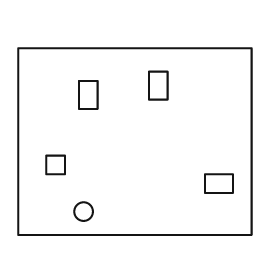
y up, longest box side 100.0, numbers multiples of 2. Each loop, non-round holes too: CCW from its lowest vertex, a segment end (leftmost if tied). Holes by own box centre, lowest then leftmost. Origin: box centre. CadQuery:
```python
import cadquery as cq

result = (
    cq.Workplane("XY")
    .moveTo(-50.0, -40.0)
    .lineTo(50.0, -40.0)
    .lineTo(50.0, 40.0)
    .lineTo(-50.0, 40.0)
    .close()
    .moveTo(-22.0, -30.0)
    .circle(4.0)
    .moveTo(30.0, -22.0)
    .lineTo(42.0, -22.0)
    .lineTo(42.0, -14.0)
    .lineTo(30.0, -14.0)
    .close()
    .moveTo(-38.0, -14.0)
    .lineTo(-30.0, -14.0)
    .lineTo(-30.0, -6.0)
    .lineTo(-38.0, -6.0)
    .close()
    .moveTo(-24.0, 14.0)
    .lineTo(-16.0, 14.0)
    .lineTo(-16.0, 26.0)
    .lineTo(-24.0, 26.0)
    .close()
    .moveTo(6.0, 18.0)
    .lineTo(14.0, 18.0)
    .lineTo(14.0, 30.0)
    .lineTo(6.0, 30.0)
    .close()
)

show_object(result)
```